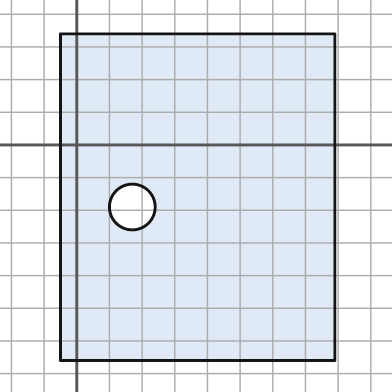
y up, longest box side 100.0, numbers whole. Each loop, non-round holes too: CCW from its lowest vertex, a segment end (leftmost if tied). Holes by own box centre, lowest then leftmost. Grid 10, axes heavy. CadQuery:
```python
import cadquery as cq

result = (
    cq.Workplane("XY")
    .moveTo(-5.0, -66.0)
    .lineTo(79.0, -66.0)
    .lineTo(79.0, 34.0)
    .lineTo(-5.0, 34.0)
    .close()
    .moveTo(17.0, -19.0)
    .circle(7.0)
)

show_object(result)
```